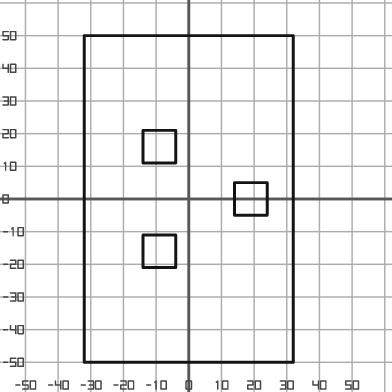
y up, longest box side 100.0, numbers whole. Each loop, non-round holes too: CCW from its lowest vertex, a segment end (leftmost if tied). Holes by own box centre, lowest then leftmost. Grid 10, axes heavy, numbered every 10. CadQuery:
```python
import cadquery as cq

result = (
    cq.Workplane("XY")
    .moveTo(-32.0, -50.0)
    .lineTo(32.0, -50.0)
    .lineTo(32.0, 50.0)
    .lineTo(-32.0, 50.0)
    .close()
    .moveTo(-14.0, -21.0)
    .lineTo(-4.0, -21.0)
    .lineTo(-4.0, -11.0)
    .lineTo(-14.0, -11.0)
    .close()
    .moveTo(14.0, -5.0)
    .lineTo(24.0, -5.0)
    .lineTo(24.0, 5.0)
    .lineTo(14.0, 5.0)
    .close()
    .moveTo(-14.0, 11.0)
    .lineTo(-4.0, 11.0)
    .lineTo(-4.0, 21.0)
    .lineTo(-14.0, 21.0)
    .close()
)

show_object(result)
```